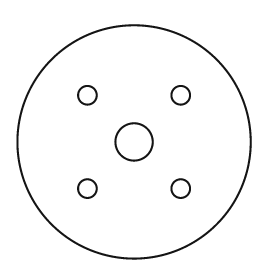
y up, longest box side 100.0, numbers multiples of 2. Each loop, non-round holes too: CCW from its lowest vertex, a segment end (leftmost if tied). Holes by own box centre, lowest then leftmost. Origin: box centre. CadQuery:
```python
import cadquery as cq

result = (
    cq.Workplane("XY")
    .moveTo(0.0, 0.0)
    .circle(50.0)
    .moveTo(-20.0, -20.0)
    .circle(4.0)
    .moveTo(20.0, -20.0)
    .circle(4.0)
    .moveTo(0.0, 0.0)
    .circle(8.0)
    .moveTo(-20.0, 20.0)
    .circle(4.0)
    .moveTo(20.0, 20.0)
    .circle(4.0)
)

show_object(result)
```